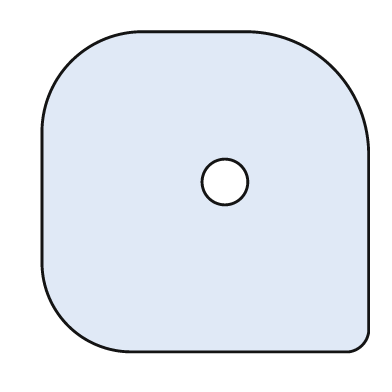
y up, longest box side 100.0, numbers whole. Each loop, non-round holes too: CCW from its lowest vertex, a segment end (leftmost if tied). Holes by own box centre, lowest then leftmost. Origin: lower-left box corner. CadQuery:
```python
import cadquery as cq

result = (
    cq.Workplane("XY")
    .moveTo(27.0, 0.0)
    .lineTo(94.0, 0.0)
    .threePointArc((98.0, 2.0), (100.0, 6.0))
    .lineTo(100.0, 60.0)
    .threePointArc((89.0, 87.0), (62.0, 98.0))
    .lineTo(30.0, 98.0)
    .threePointArc((9.0, 89.0), (0.0, 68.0))
    .lineTo(0.0, 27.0)
    .threePointArc((8.0, 8.0), (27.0, 0.0))
    .close()
    .moveTo(56.0, 52.0)
    .circle(7.0)
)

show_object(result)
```